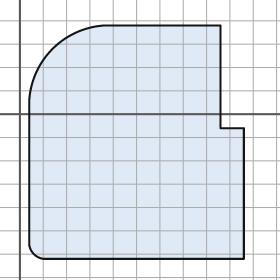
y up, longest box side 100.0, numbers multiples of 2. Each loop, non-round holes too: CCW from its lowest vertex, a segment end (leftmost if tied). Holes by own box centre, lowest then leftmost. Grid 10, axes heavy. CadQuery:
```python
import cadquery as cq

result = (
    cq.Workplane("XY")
    .moveTo(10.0, -62.0)
    .lineTo(96.0, -62.0)
    .lineTo(96.0, -6.0)
    .lineTo(86.0, -6.0)
    .lineTo(86.0, 38.0)
    .lineTo(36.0, 38.0)
    .threePointArc((14.0, 28.0), (4.0, 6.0))
    .lineTo(4.0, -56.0)
    .threePointArc((6.0, -60.0), (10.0, -62.0))
    .close()
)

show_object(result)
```